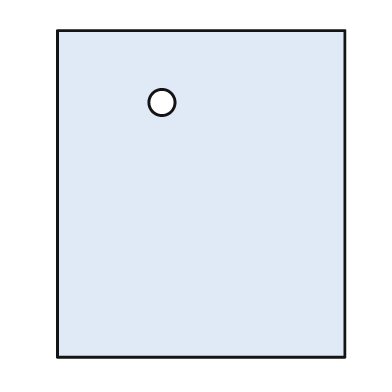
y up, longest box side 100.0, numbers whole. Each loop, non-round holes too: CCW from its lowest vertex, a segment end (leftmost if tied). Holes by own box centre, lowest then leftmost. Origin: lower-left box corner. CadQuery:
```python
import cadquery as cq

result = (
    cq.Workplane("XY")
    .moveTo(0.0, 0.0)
    .lineTo(88.0, 0.0)
    .lineTo(88.0, 100.0)
    .lineTo(0.0, 100.0)
    .close()
    .moveTo(32.0, 78.0)
    .circle(4.0)
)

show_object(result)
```